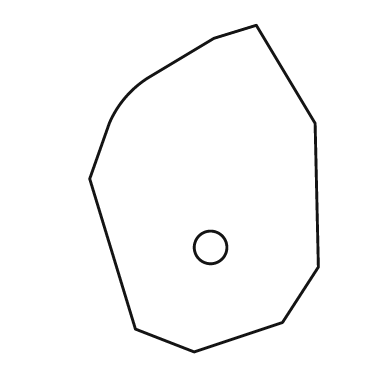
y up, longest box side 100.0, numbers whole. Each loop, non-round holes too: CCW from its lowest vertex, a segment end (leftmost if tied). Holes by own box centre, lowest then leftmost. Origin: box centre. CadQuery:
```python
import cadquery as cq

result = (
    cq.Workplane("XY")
    .moveTo(-3.0, -50.0)
    .lineTo(24.0, -41.0)
    .lineTo(35.0, -24.0)
    .lineTo(34.0, 20.0)
    .lineTo(16.0, 50.0)
    .lineTo(3.0, 46.0)
    .lineTo(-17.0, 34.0)
    .threePointArc((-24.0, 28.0), (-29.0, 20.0))
    .lineTo(-35.0, 3.0)
    .lineTo(-21.0, -43.0)
    .close()
    .moveTo(2.0, -18.0)
    .circle(5.0)
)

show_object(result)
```